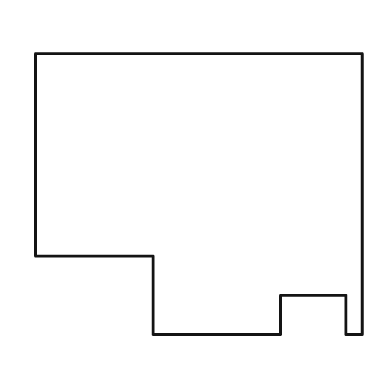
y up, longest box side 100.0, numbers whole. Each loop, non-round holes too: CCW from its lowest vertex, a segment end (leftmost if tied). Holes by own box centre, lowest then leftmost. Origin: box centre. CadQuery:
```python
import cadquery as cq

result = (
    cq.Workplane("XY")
    .moveTo(-14.0, -43.0)
    .lineTo(25.0, -43.0)
    .lineTo(25.0, -31.0)
    .lineTo(45.0, -31.0)
    .lineTo(45.0, -43.0)
    .lineTo(50.0, -43.0)
    .lineTo(50.0, 43.0)
    .lineTo(-50.0, 43.0)
    .lineTo(-50.0, -19.0)
    .lineTo(-14.0, -19.0)
    .close()
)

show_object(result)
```